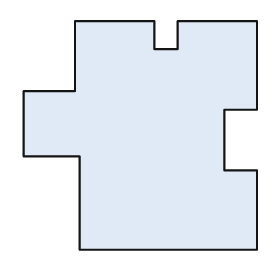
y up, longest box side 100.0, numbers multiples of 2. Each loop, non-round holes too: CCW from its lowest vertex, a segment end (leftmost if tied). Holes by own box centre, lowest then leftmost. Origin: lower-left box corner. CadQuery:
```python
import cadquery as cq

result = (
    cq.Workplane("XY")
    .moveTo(24.0, 0.0)
    .lineTo(100.0, 0.0)
    .lineTo(100.0, 34.0)
    .lineTo(86.0, 34.0)
    .lineTo(86.0, 60.0)
    .lineTo(100.0, 60.0)
    .lineTo(100.0, 98.0)
    .lineTo(66.0, 98.0)
    .lineTo(66.0, 86.0)
    .lineTo(56.0, 86.0)
    .lineTo(56.0, 98.0)
    .lineTo(22.0, 98.0)
    .lineTo(22.0, 68.0)
    .lineTo(0.0, 68.0)
    .lineTo(0.0, 40.0)
    .lineTo(24.0, 40.0)
    .close()
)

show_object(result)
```